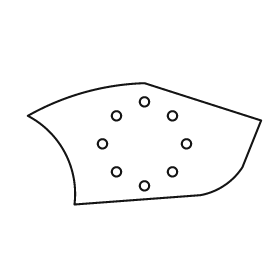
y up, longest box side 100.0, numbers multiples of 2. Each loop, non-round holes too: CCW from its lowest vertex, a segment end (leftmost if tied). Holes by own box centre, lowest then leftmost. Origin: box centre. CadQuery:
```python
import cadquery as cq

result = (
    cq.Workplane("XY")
    .moveTo(-30.0, -26.0)
    .lineTo(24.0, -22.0)
    .threePointArc((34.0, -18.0), (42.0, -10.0))
    .lineTo(50.0, 10.0)
    .lineTo(0.0, 26.0)
    .threePointArc((-26.0, 22.0), (-50.0, 12.0))
    .threePointArc((-34.0, -4.0), (-30.0, -26.0))
    .close()
    .moveTo(0.0, -18.0)
    .circle(2.0)
    .moveTo(-12.0, -12.0)
    .circle(2.0)
    .moveTo(12.0, -12.0)
    .circle(2.0)
    .moveTo(-18.0, 0.0)
    .circle(2.0)
    .moveTo(18.0, 0.0)
    .circle(2.0)
    .moveTo(-12.0, 12.0)
    .circle(2.0)
    .moveTo(12.0, 12.0)
    .circle(2.0)
    .moveTo(0.0, 18.0)
    .circle(2.0)
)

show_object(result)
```